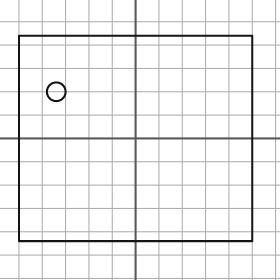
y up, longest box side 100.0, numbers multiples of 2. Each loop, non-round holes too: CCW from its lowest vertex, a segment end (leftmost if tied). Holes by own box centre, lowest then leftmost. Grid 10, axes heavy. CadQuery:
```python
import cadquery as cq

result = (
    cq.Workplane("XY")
    .moveTo(-50.0, -44.0)
    .lineTo(50.0, -44.0)
    .lineTo(50.0, 44.0)
    .lineTo(-50.0, 44.0)
    .close()
    .moveTo(-34.0, 20.0)
    .circle(4.0)
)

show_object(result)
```